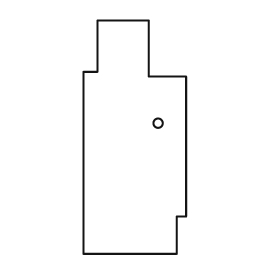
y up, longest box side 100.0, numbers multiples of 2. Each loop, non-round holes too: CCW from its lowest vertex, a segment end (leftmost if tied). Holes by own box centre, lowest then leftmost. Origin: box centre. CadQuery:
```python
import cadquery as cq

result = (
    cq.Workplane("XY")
    .moveTo(-22.0, -50.0)
    .lineTo(18.0, -50.0)
    .lineTo(18.0, -34.0)
    .lineTo(22.0, -34.0)
    .lineTo(22.0, 26.0)
    .lineTo(6.0, 26.0)
    .lineTo(6.0, 50.0)
    .lineTo(-16.0, 50.0)
    .lineTo(-16.0, 28.0)
    .lineTo(-22.0, 28.0)
    .close()
    .moveTo(10.0, 6.0)
    .circle(2.0)
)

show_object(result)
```